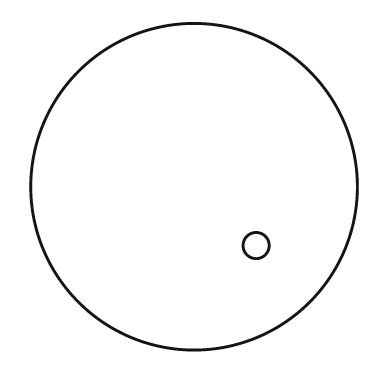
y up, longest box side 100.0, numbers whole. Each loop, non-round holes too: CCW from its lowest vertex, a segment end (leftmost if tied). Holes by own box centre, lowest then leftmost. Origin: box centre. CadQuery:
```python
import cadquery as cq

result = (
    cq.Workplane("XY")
    .moveTo(0.0, 0.0)
    .circle(50.0)
    .moveTo(19.0, -18.0)
    .circle(4.0)
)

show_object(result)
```